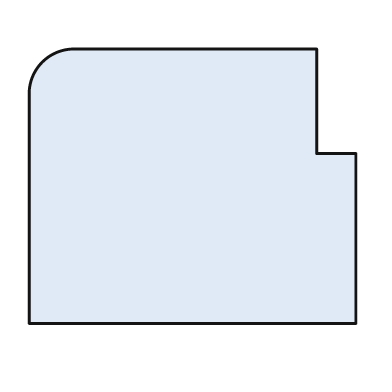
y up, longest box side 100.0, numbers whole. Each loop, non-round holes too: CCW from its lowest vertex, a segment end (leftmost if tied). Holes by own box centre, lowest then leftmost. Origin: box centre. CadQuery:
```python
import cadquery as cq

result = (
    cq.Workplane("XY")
    .moveTo(-50.0, -42.0)
    .lineTo(50.0, -42.0)
    .lineTo(50.0, 10.0)
    .lineTo(38.0, 10.0)
    .lineTo(38.0, 42.0)
    .lineTo(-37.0, 42.0)
    .threePointArc((-46.0, 38.0), (-50.0, 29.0))
    .close()
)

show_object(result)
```